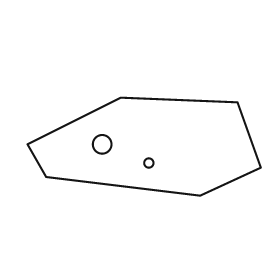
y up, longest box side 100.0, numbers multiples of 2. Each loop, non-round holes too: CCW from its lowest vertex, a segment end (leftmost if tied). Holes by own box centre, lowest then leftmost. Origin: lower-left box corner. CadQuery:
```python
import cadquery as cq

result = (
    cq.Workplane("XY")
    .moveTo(74.0, 0.0)
    .lineTo(100.0, 12.0)
    .lineTo(90.0, 40.0)
    .lineTo(40.0, 42.0)
    .lineTo(0.0, 22.0)
    .lineTo(8.0, 8.0)
    .close()
    .moveTo(52.0, 14.0)
    .circle(2.0)
    .moveTo(32.0, 22.0)
    .circle(4.0)
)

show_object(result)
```